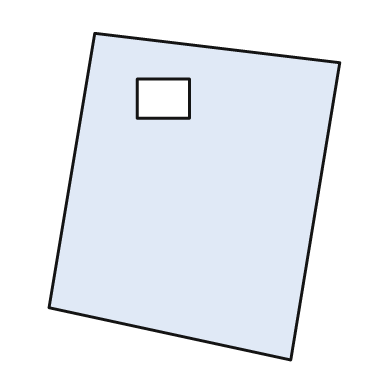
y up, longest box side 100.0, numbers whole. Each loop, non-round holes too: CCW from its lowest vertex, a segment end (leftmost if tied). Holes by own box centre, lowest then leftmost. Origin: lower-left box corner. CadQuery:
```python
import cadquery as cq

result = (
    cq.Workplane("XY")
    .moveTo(74.0, 0.0)
    .lineTo(89.0, 91.0)
    .lineTo(14.0, 100.0)
    .lineTo(0.0, 16.0)
    .close()
    .moveTo(27.0, 74.0)
    .lineTo(43.0, 74.0)
    .lineTo(43.0, 86.0)
    .lineTo(27.0, 86.0)
    .close()
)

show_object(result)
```